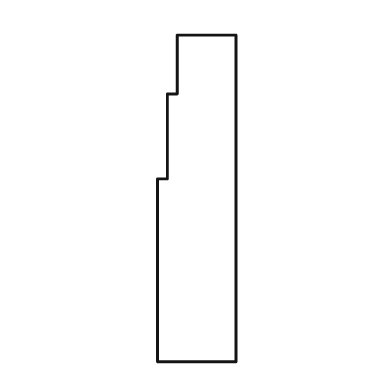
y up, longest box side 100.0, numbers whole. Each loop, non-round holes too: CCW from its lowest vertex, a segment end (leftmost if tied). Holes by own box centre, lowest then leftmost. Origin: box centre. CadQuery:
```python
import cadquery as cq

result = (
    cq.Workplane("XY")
    .moveTo(-12.0, -50.0)
    .lineTo(12.0, -50.0)
    .lineTo(12.0, 50.0)
    .lineTo(-6.0, 50.0)
    .lineTo(-6.0, 32.0)
    .lineTo(-9.0, 32.0)
    .lineTo(-9.0, 6.0)
    .lineTo(-12.0, 6.0)
    .close()
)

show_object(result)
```